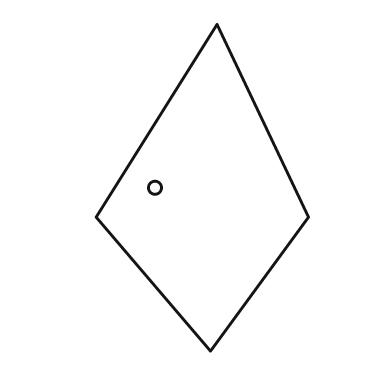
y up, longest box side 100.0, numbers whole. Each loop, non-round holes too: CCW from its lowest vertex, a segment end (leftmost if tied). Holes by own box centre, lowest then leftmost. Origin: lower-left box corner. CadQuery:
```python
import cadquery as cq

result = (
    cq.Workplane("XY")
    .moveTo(35.0, 0.0)
    .lineTo(65.0, 41.0)
    .lineTo(37.0, 100.0)
    .lineTo(0.0, 41.0)
    .close()
    .moveTo(18.0, 50.0)
    .circle(2.0)
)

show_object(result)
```